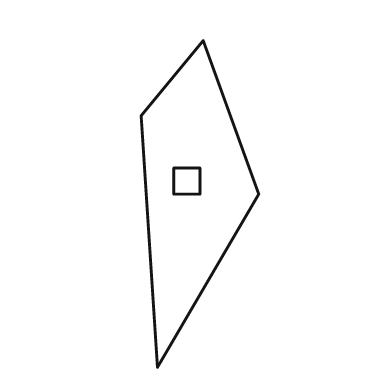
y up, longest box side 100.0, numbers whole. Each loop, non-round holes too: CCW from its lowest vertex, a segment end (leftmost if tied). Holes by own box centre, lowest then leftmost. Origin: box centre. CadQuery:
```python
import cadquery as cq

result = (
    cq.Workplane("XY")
    .moveTo(-13.0, -50.0)
    .lineTo(18.0, 3.0)
    .lineTo(1.0, 50.0)
    .lineTo(-18.0, 27.0)
    .close()
    .moveTo(-8.0, 3.0)
    .lineTo(0.0, 3.0)
    .lineTo(0.0, 11.0)
    .lineTo(-8.0, 11.0)
    .close()
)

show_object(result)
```